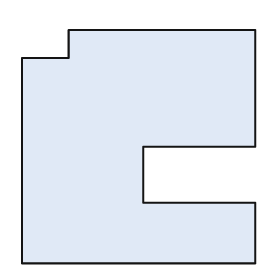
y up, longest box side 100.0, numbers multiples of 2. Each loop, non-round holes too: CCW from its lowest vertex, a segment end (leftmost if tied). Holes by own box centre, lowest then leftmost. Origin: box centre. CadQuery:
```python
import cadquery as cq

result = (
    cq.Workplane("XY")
    .moveTo(-50.0, -50.0)
    .lineTo(50.0, -50.0)
    .lineTo(50.0, -24.0)
    .lineTo(2.0, -24.0)
    .lineTo(2.0, 0.0)
    .lineTo(50.0, 0.0)
    .lineTo(50.0, 50.0)
    .lineTo(-30.0, 50.0)
    .lineTo(-30.0, 38.0)
    .lineTo(-50.0, 38.0)
    .close()
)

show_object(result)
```